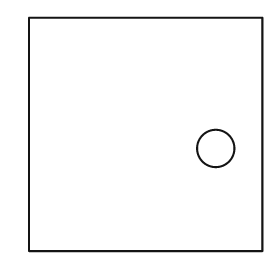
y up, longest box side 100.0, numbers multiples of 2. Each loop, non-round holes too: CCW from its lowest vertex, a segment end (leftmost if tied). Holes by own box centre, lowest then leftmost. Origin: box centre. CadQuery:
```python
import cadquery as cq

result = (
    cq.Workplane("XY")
    .moveTo(-50.0, -50.0)
    .lineTo(50.0, -50.0)
    .lineTo(50.0, 50.0)
    .lineTo(-50.0, 50.0)
    .close()
    .moveTo(30.0, -6.0)
    .circle(8.0)
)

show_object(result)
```